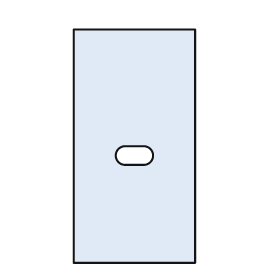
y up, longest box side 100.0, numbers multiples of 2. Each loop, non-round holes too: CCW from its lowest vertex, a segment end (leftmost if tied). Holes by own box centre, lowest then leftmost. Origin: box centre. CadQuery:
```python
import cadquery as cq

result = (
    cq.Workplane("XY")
    .moveTo(-26.0, -50.0)
    .lineTo(26.0, -50.0)
    .lineTo(26.0, 50.0)
    .lineTo(-26.0, 50.0)
    .close()
    .moveTo(-4.0, -8.0)
    .lineTo(4.0, -8.0)
    .threePointArc((8.0, -4.0), (4.0, 0.0))
    .lineTo(-4.0, 0.0)
    .threePointArc((-8.0, -4.0), (-4.0, -8.0))
    .close()
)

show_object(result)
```